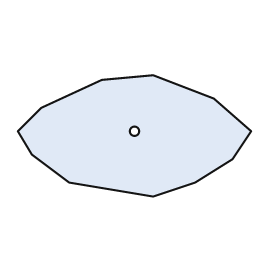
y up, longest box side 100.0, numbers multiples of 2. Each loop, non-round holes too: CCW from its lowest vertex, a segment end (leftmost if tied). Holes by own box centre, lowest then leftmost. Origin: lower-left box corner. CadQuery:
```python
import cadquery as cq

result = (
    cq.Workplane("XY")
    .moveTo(58.0, 0.0)
    .lineTo(76.0, 6.0)
    .lineTo(92.0, 16.0)
    .lineTo(100.0, 28.0)
    .lineTo(84.0, 42.0)
    .lineTo(58.0, 52.0)
    .lineTo(36.0, 50.0)
    .lineTo(10.0, 38.0)
    .lineTo(0.0, 28.0)
    .lineTo(6.0, 18.0)
    .lineTo(22.0, 6.0)
    .close()
    .moveTo(50.0, 28.0)
    .circle(2.0)
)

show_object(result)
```